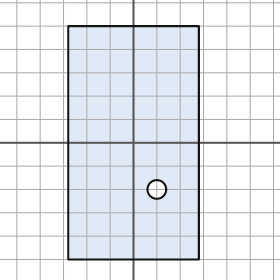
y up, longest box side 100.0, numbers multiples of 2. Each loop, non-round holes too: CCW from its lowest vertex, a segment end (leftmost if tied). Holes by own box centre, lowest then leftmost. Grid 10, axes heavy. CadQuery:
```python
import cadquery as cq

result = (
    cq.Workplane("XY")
    .moveTo(-28.0, -50.0)
    .lineTo(28.0, -50.0)
    .lineTo(28.0, 50.0)
    .lineTo(-28.0, 50.0)
    .close()
    .moveTo(10.0, -20.0)
    .circle(4.0)
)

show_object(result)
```